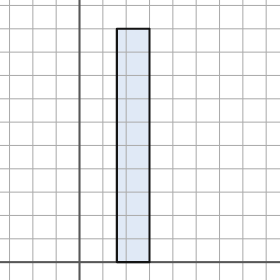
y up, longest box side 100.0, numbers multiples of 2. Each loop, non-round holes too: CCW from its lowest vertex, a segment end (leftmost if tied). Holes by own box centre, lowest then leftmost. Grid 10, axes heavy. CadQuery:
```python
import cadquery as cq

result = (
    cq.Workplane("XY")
    .moveTo(16.0, 0.0)
    .lineTo(30.0, 0.0)
    .lineTo(30.0, 100.0)
    .lineTo(16.0, 100.0)
    .close()
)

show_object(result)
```